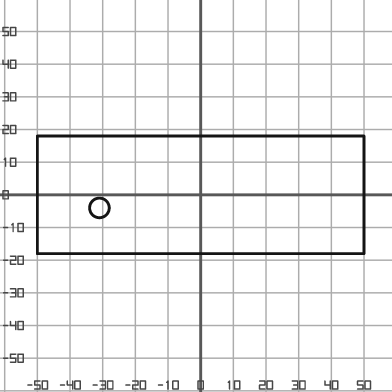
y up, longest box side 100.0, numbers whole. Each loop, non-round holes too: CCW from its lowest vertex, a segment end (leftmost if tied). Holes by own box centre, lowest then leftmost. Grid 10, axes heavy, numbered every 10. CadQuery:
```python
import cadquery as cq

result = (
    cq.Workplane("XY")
    .moveTo(-50.0, -18.0)
    .lineTo(50.0, -18.0)
    .lineTo(50.0, 18.0)
    .lineTo(-50.0, 18.0)
    .close()
    .moveTo(-31.0, -4.0)
    .circle(3.0)
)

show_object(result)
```